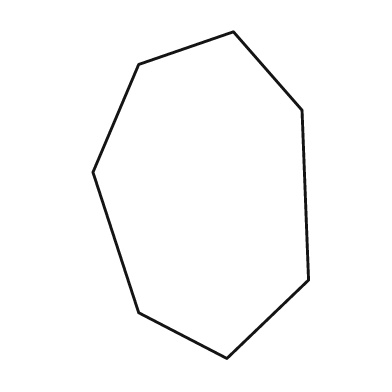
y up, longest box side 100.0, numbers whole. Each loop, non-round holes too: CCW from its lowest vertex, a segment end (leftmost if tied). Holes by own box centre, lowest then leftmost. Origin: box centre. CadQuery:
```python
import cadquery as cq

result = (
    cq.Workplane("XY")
    .moveTo(8.0, -50.0)
    .lineTo(33.0, -26.0)
    .lineTo(31.0, 26.0)
    .lineTo(10.0, 50.0)
    .lineTo(-19.0, 40.0)
    .lineTo(-33.0, 7.0)
    .lineTo(-19.0, -36.0)
    .close()
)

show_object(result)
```